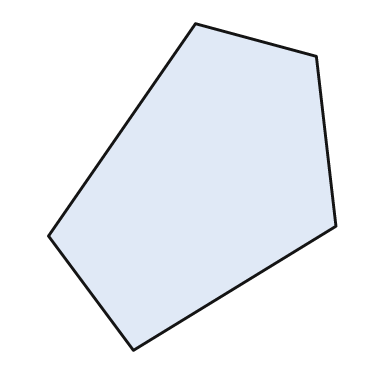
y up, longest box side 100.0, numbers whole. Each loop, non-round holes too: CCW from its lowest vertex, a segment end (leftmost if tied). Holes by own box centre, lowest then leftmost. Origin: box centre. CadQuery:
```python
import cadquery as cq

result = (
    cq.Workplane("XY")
    .moveTo(-18.0, -50.0)
    .lineTo(44.0, -12.0)
    .lineTo(38.0, 40.0)
    .lineTo(1.0, 50.0)
    .lineTo(-44.0, -15.0)
    .close()
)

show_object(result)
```